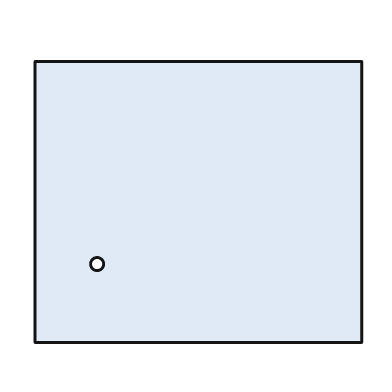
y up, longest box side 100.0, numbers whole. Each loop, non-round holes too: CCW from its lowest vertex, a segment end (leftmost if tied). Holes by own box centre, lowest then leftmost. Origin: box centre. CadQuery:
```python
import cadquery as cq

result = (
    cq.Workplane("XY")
    .moveTo(-50.0, -43.0)
    .lineTo(50.0, -43.0)
    .lineTo(50.0, 43.0)
    .lineTo(-50.0, 43.0)
    .close()
    .moveTo(-31.0, -19.0)
    .circle(2.0)
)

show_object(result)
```